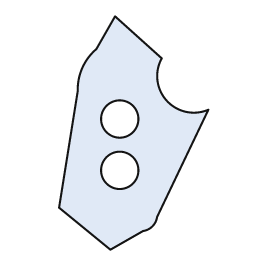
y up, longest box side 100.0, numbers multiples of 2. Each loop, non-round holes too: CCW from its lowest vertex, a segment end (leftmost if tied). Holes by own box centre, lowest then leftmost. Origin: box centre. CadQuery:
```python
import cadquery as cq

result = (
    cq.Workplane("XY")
    .moveTo(-10.0, -50.0)
    .lineTo(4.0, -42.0)
    .threePointArc((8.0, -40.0), (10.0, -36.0))
    .lineTo(32.0, 10.0)
    .threePointArc((14.0, 14.0), (12.0, 32.0))
    .lineTo(-8.0, 50.0)
    .lineTo(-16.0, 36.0)
    .threePointArc((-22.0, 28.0), (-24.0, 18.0))
    .lineTo(-32.0, -32.0)
    .close()
    .moveTo(-6.0, -16.0)
    .circle(8.0)
    .moveTo(-6.0, 6.0)
    .circle(8.0)
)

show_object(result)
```